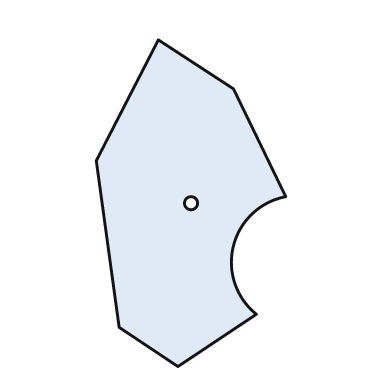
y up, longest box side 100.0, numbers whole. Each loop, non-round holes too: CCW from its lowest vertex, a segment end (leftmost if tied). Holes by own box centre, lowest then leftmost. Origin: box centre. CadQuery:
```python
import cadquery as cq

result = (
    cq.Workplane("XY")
    .moveTo(-4.0, -50.0)
    .lineTo(20.0, -34.0)
    .threePointArc((13.0, -13.0), (29.0, 2.0))
    .lineTo(13.0, 35.0)
    .lineTo(-10.0, 50.0)
    .lineTo(-29.0, 13.0)
    .lineTo(-22.0, -38.0)
    .close()
    .moveTo(0.0, 0.0)
    .circle(2.0)
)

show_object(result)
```